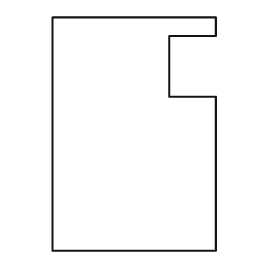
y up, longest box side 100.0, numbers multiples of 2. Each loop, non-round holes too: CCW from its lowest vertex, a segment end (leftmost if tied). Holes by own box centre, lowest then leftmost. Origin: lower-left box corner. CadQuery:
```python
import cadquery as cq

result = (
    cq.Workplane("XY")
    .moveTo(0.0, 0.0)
    .lineTo(70.0, 0.0)
    .lineTo(70.0, 66.0)
    .lineTo(50.0, 66.0)
    .lineTo(50.0, 92.0)
    .lineTo(70.0, 92.0)
    .lineTo(70.0, 100.0)
    .lineTo(0.0, 100.0)
    .close()
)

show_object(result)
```